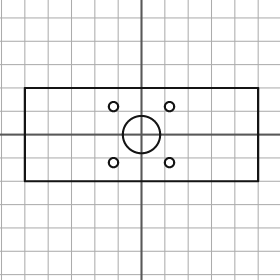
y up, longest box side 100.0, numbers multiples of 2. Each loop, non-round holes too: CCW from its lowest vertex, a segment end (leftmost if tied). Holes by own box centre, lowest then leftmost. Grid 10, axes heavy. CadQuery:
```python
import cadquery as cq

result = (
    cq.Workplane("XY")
    .moveTo(-50.0, -20.0)
    .lineTo(50.0, -20.0)
    .lineTo(50.0, 20.0)
    .lineTo(-50.0, 20.0)
    .close()
    .moveTo(-12.0, -12.0)
    .circle(2.0)
    .moveTo(12.0, -12.0)
    .circle(2.0)
    .moveTo(0.0, 0.0)
    .circle(8.0)
    .moveTo(-12.0, 12.0)
    .circle(2.0)
    .moveTo(12.0, 12.0)
    .circle(2.0)
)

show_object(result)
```